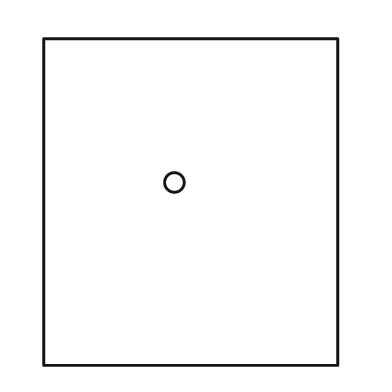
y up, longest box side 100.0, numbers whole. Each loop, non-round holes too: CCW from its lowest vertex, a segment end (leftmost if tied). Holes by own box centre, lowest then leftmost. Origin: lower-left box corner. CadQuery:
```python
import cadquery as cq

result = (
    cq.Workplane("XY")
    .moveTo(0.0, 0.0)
    .lineTo(90.0, 0.0)
    .lineTo(90.0, 100.0)
    .lineTo(0.0, 100.0)
    .close()
    .moveTo(40.0, 56.0)
    .circle(3.0)
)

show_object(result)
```